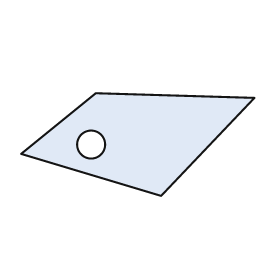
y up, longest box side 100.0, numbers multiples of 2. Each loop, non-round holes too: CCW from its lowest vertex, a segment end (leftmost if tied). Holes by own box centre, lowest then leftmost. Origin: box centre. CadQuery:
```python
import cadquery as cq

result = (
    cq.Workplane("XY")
    .moveTo(10.0, -22.0)
    .lineTo(50.0, 20.0)
    .lineTo(-18.0, 22.0)
    .lineTo(-50.0, -4.0)
    .close()
    .moveTo(-20.0, 0.0)
    .circle(6.0)
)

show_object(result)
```